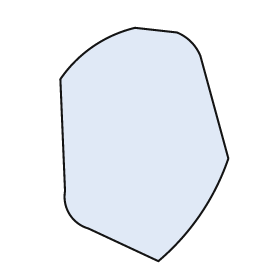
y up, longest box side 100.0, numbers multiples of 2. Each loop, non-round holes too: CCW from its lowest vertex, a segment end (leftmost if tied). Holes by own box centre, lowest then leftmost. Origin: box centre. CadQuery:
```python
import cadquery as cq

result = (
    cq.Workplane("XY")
    .moveTo(6.0, -50.0)
    .threePointArc((24.0, -30.0), (36.0, -6.0))
    .lineTo(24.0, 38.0)
    .threePointArc((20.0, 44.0), (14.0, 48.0))
    .lineTo(-4.0, 50.0)
    .threePointArc((-22.0, 42.0), (-36.0, 28.0))
    .lineTo(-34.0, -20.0)
    .threePointArc((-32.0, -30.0), (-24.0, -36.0))
    .close()
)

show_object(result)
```